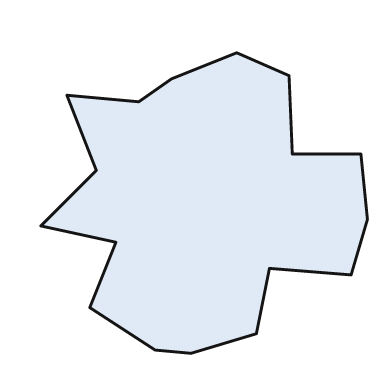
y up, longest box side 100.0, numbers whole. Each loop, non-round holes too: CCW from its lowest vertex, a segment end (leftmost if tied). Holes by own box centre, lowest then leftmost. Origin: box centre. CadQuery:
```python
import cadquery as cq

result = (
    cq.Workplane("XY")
    .moveTo(-4.0, -46.0)
    .lineTo(16.0, -40.0)
    .lineTo(20.0, -20.0)
    .lineTo(45.0, -22.0)
    .lineTo(50.0, -5.0)
    .lineTo(48.0, 15.0)
    .lineTo(27.0, 15.0)
    .lineTo(26.0, 39.0)
    .lineTo(10.0, 46.0)
    .lineTo(-10.0, 38.0)
    .lineTo(-20.0, 31.0)
    .lineTo(-42.0, 33.0)
    .lineTo(-33.0, 10.0)
    .lineTo(-50.0, -7.0)
    .lineTo(-27.0, -12.0)
    .lineTo(-35.0, -32.0)
    .lineTo(-15.0, -45.0)
    .close()
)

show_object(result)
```